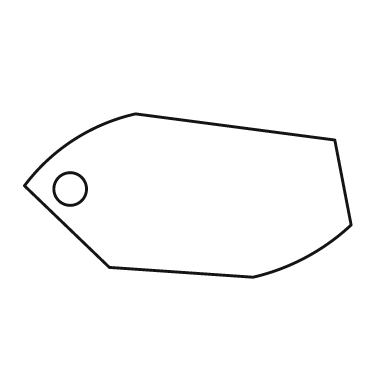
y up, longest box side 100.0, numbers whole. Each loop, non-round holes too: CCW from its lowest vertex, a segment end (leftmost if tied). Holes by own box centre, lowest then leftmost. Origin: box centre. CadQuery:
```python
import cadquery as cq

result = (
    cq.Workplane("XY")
    .moveTo(20.0, -25.0)
    .threePointArc((36.0, -19.0), (50.0, -9.0))
    .lineTo(45.0, 17.0)
    .lineTo(-16.0, 25.0)
    .threePointArc((-35.0, 17.0), (-50.0, 3.0))
    .lineTo(-24.0, -22.0)
    .close()
    .moveTo(-36.0, 2.0)
    .circle(5.0)
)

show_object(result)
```